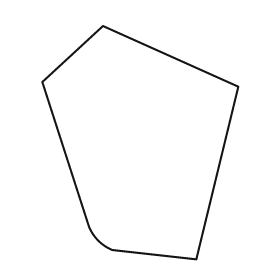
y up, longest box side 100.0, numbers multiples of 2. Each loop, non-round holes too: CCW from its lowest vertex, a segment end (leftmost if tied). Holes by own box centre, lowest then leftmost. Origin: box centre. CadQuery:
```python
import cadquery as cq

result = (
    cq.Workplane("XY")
    .moveTo(24.0, -50.0)
    .lineTo(42.0, 24.0)
    .lineTo(-16.0, 50.0)
    .lineTo(-42.0, 26.0)
    .lineTo(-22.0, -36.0)
    .threePointArc((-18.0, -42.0), (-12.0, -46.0))
    .close()
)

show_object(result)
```